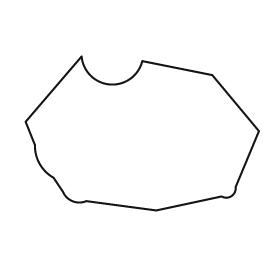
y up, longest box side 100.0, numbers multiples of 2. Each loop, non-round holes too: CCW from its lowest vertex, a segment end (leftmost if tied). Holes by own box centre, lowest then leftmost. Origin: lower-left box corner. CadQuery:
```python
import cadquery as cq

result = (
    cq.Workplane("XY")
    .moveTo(56.0, 0.0)
    .lineTo(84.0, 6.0)
    .threePointArc((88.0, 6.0), (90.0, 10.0))
    .lineTo(100.0, 34.0)
    .lineTo(80.0, 58.0)
    .lineTo(50.0, 64.0)
    .threePointArc((36.0, 54.0), (24.0, 66.0))
    .lineTo(0.0, 38.0)
    .lineTo(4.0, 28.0)
    .threePointArc((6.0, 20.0), (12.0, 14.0))
    .lineTo(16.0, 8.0)
    .threePointArc((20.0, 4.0), (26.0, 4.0))
    .close()
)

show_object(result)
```